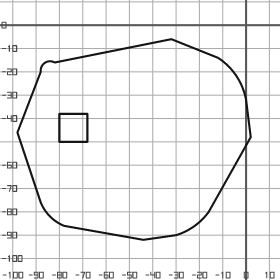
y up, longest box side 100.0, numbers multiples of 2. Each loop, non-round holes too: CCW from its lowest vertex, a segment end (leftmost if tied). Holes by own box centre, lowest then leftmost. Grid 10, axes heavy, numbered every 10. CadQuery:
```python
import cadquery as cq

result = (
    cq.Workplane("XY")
    .moveTo(-44.0, -92.0)
    .lineTo(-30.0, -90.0)
    .threePointArc((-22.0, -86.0), (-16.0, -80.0))
    .lineTo(2.0, -48.0)
    .lineTo(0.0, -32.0)
    .threePointArc((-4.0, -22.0), (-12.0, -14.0))
    .lineTo(-32.0, -6.0)
    .lineTo(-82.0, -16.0)
    .threePointArc((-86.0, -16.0), (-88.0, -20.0))
    .lineTo(-98.0, -46.0)
    .lineTo(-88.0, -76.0)
    .threePointArc((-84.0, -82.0), (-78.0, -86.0))
    .close()
    .moveTo(-80.0, -50.0)
    .lineTo(-68.0, -50.0)
    .lineTo(-68.0, -38.0)
    .lineTo(-80.0, -38.0)
    .close()
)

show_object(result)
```